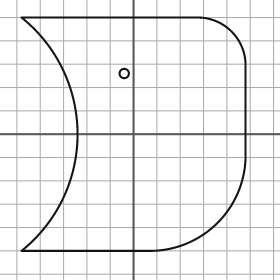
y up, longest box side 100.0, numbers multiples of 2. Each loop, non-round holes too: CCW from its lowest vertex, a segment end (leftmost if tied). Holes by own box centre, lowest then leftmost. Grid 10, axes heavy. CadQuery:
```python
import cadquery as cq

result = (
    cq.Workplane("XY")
    .moveTo(-48.0, -50.0)
    .lineTo(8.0, -50.0)
    .threePointArc((36.0, -38.0), (48.0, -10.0))
    .lineTo(48.0, 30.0)
    .threePointArc((42.0, 44.0), (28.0, 50.0))
    .lineTo(-48.0, 50.0)
    .threePointArc((-24.0, 0.0), (-48.0, -50.0))
    .close()
    .moveTo(-4.0, 26.0)
    .circle(2.0)
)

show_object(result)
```